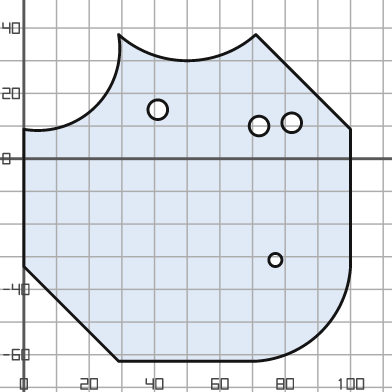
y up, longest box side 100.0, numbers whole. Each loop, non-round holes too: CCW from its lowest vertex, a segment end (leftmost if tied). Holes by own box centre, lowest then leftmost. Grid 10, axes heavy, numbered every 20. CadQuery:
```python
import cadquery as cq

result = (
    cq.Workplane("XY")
    .moveTo(29.0, -62.0)
    .lineTo(71.0, -62.0)
    .threePointArc((91.0, -53.0), (100.0, -33.0))
    .lineTo(100.0, 9.0)
    .lineTo(71.0, 38.0)
    .threePointArc((50.0, 30.0), (29.0, 38.0))
    .threePointArc((22.0, 16.0), (0.0, 9.0))
    .lineTo(0.0, -33.0)
    .close()
    .moveTo(77.0, -31.0)
    .circle(2.0)
    .moveTo(72.0, 10.0)
    .circle(3.0)
    .moveTo(82.0, 11.0)
    .circle(3.0)
    .moveTo(41.0, 15.0)
    .circle(3.0)
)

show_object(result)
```